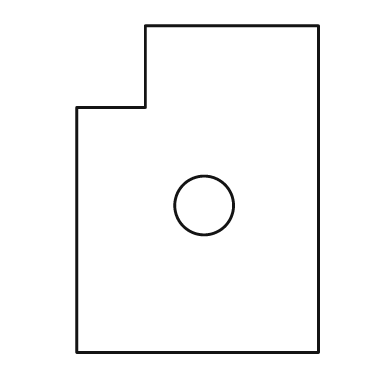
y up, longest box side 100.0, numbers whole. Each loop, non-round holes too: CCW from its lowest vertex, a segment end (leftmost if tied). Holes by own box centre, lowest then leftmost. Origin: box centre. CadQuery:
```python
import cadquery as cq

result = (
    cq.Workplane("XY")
    .moveTo(-37.0, -50.0)
    .lineTo(37.0, -50.0)
    .lineTo(37.0, 50.0)
    .lineTo(-16.0, 50.0)
    .lineTo(-16.0, 25.0)
    .lineTo(-37.0, 25.0)
    .close()
    .moveTo(2.0, -5.0)
    .circle(9.0)
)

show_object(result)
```